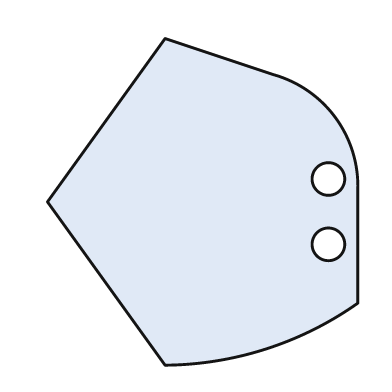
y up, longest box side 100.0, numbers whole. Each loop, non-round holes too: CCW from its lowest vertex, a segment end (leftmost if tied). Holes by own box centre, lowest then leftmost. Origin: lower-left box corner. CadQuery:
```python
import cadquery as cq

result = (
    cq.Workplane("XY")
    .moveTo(36.0, 0.0)
    .threePointArc((67.0, 5.0), (95.0, 19.0))
    .lineTo(95.0, 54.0)
    .threePointArc((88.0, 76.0), (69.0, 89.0))
    .lineTo(36.0, 100.0)
    .lineTo(0.0, 50.0)
    .close()
    .moveTo(86.0, 37.0)
    .circle(5.0)
    .moveTo(86.0, 57.0)
    .circle(5.0)
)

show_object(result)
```